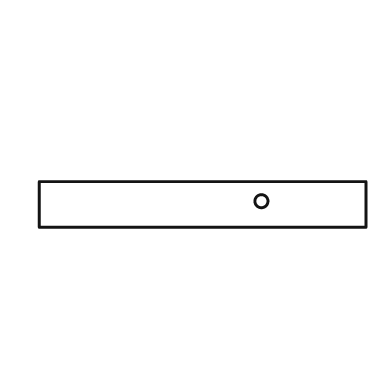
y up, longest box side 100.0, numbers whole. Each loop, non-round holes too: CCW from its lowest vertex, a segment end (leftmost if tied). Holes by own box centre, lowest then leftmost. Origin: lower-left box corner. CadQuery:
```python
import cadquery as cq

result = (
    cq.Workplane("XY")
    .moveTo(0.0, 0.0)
    .lineTo(100.0, 0.0)
    .lineTo(100.0, 14.0)
    .lineTo(0.0, 14.0)
    .close()
    .moveTo(68.0, 8.0)
    .circle(2.0)
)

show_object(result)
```